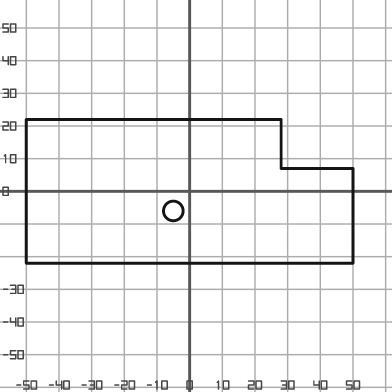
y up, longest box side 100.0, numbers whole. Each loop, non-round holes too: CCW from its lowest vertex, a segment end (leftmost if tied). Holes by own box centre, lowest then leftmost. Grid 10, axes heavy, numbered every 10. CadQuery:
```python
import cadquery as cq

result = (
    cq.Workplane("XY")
    .moveTo(-50.0, -22.0)
    .lineTo(50.0, -22.0)
    .lineTo(50.0, 7.0)
    .lineTo(28.0, 7.0)
    .lineTo(28.0, 22.0)
    .lineTo(-50.0, 22.0)
    .close()
    .moveTo(-5.0, -6.0)
    .circle(3.0)
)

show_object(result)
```